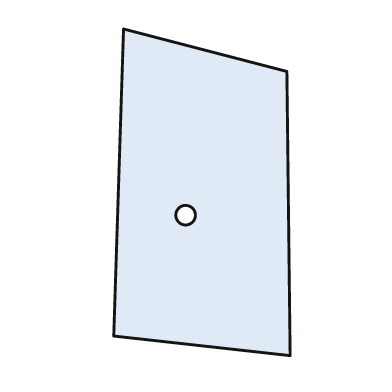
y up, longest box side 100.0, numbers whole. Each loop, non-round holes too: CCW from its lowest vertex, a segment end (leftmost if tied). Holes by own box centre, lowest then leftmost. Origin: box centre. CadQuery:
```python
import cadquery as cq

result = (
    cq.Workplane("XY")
    .moveTo(27.0, -50.0)
    .lineTo(26.0, 37.0)
    .lineTo(-24.0, 50.0)
    .lineTo(-27.0, -44.0)
    .close()
    .moveTo(-5.0, -7.0)
    .circle(3.0)
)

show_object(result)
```